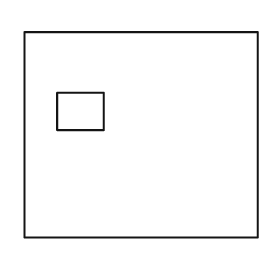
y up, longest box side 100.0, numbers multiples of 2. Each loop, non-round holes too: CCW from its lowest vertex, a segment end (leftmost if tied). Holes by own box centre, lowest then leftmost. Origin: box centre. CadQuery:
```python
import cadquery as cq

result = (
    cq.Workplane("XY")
    .moveTo(-50.0, -44.0)
    .lineTo(50.0, -44.0)
    .lineTo(50.0, 44.0)
    .lineTo(-50.0, 44.0)
    .close()
    .moveTo(-36.0, 2.0)
    .lineTo(-16.0, 2.0)
    .lineTo(-16.0, 18.0)
    .lineTo(-36.0, 18.0)
    .close()
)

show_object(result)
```